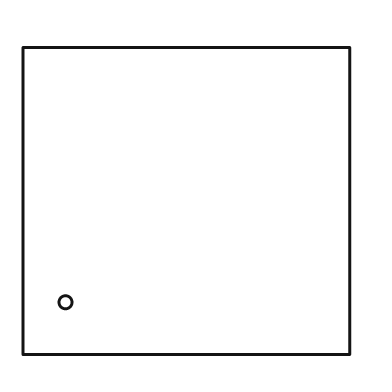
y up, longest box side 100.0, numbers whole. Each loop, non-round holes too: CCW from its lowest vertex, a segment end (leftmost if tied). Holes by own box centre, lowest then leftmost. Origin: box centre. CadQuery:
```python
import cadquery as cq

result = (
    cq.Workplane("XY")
    .moveTo(-50.0, -47.0)
    .lineTo(50.0, -47.0)
    .lineTo(50.0, 47.0)
    .lineTo(-50.0, 47.0)
    .close()
    .moveTo(-37.0, -31.0)
    .circle(2.0)
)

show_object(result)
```